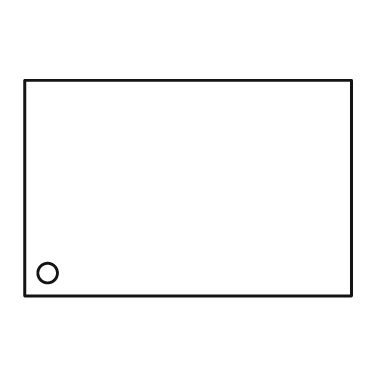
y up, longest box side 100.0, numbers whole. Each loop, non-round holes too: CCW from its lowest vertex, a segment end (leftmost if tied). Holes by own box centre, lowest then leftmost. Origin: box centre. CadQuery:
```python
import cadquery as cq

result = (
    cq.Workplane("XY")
    .moveTo(-50.0, -33.0)
    .lineTo(50.0, -33.0)
    .lineTo(50.0, 33.0)
    .lineTo(-50.0, 33.0)
    .close()
    .moveTo(-43.0, -26.0)
    .circle(3.0)
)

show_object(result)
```